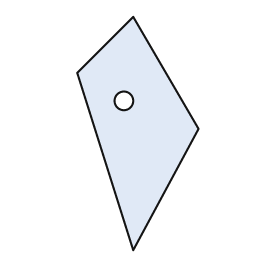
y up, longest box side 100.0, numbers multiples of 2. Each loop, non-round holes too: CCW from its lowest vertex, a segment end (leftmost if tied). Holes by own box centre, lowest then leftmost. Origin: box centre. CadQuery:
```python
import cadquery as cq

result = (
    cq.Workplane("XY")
    .moveTo(-2.0, -50.0)
    .lineTo(26.0, 2.0)
    .lineTo(-2.0, 50.0)
    .lineTo(-26.0, 26.0)
    .close()
    .moveTo(-6.0, 14.0)
    .circle(4.0)
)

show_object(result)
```